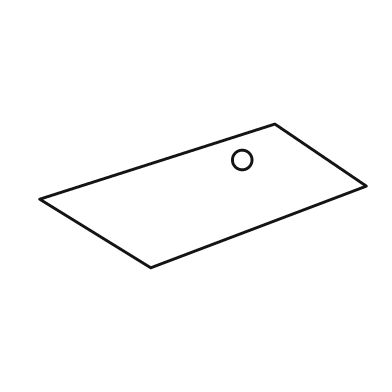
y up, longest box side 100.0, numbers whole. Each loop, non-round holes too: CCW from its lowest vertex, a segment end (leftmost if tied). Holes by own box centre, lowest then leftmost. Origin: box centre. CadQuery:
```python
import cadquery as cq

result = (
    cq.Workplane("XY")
    .moveTo(-16.0, -22.0)
    .lineTo(50.0, 3.0)
    .lineTo(22.0, 22.0)
    .lineTo(-50.0, -1.0)
    .close()
    .moveTo(12.0, 11.0)
    .circle(3.0)
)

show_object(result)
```